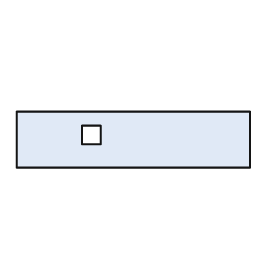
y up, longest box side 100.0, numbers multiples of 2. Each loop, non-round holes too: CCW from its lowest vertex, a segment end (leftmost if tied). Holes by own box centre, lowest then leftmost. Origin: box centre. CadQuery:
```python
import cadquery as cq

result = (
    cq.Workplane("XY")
    .moveTo(-50.0, -12.0)
    .lineTo(50.0, -12.0)
    .lineTo(50.0, 12.0)
    .lineTo(-50.0, 12.0)
    .close()
    .moveTo(-22.0, -2.0)
    .lineTo(-14.0, -2.0)
    .lineTo(-14.0, 6.0)
    .lineTo(-22.0, 6.0)
    .close()
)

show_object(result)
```